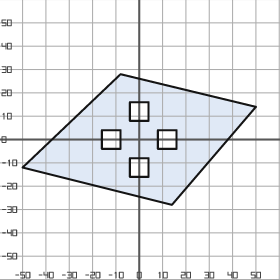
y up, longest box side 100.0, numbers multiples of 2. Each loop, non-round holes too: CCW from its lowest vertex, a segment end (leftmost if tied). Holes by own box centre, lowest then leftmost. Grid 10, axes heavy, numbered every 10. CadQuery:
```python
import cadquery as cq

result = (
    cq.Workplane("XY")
    .moveTo(14.0, -28.0)
    .lineTo(50.0, 14.0)
    .lineTo(-8.0, 28.0)
    .lineTo(-50.0, -12.0)
    .close()
    .moveTo(-4.0, -16.0)
    .lineTo(4.0, -16.0)
    .lineTo(4.0, -8.0)
    .lineTo(-4.0, -8.0)
    .close()
    .moveTo(-16.0, -4.0)
    .lineTo(-8.0, -4.0)
    .lineTo(-8.0, 4.0)
    .lineTo(-16.0, 4.0)
    .close()
    .moveTo(8.0, -4.0)
    .lineTo(16.0, -4.0)
    .lineTo(16.0, 4.0)
    .lineTo(8.0, 4.0)
    .close()
    .moveTo(-4.0, 8.0)
    .lineTo(4.0, 8.0)
    .lineTo(4.0, 16.0)
    .lineTo(-4.0, 16.0)
    .close()
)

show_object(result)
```